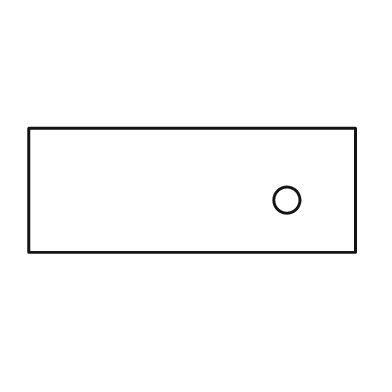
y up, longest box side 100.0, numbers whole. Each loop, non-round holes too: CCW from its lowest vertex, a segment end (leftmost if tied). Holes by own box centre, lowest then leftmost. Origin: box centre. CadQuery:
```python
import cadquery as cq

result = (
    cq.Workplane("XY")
    .moveTo(-50.0, -19.0)
    .lineTo(50.0, -19.0)
    .lineTo(50.0, 19.0)
    .lineTo(-50.0, 19.0)
    .close()
    .moveTo(29.0, -3.0)
    .circle(4.0)
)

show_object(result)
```